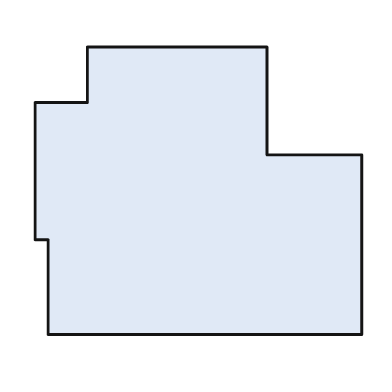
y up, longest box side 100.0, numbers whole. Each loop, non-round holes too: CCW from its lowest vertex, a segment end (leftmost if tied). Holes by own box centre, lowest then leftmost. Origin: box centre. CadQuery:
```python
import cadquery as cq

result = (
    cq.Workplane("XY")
    .moveTo(-46.0, -44.0)
    .lineTo(50.0, -44.0)
    .lineTo(50.0, 11.0)
    .lineTo(21.0, 11.0)
    .lineTo(21.0, 44.0)
    .lineTo(-34.0, 44.0)
    .lineTo(-34.0, 27.0)
    .lineTo(-50.0, 27.0)
    .lineTo(-50.0, -15.0)
    .lineTo(-46.0, -15.0)
    .close()
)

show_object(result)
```